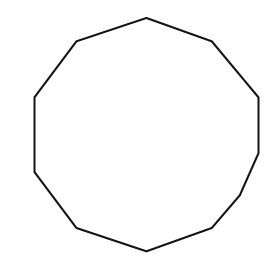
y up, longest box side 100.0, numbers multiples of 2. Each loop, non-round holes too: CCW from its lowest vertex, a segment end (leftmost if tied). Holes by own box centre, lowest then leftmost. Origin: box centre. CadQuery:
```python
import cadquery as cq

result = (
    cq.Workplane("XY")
    .moveTo(0.0, -50.0)
    .lineTo(28.0, -40.0)
    .lineTo(40.0, -26.0)
    .lineTo(48.0, -8.0)
    .lineTo(48.0, 16.0)
    .lineTo(28.0, 40.0)
    .lineTo(0.0, 50.0)
    .lineTo(-30.0, 40.0)
    .lineTo(-48.0, 16.0)
    .lineTo(-48.0, -16.0)
    .lineTo(-30.0, -40.0)
    .close()
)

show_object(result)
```